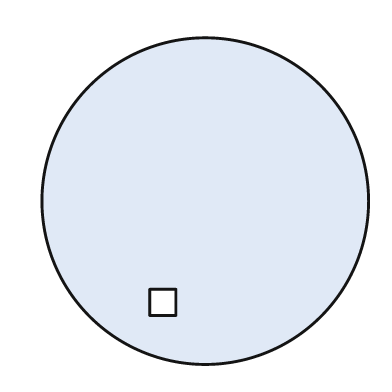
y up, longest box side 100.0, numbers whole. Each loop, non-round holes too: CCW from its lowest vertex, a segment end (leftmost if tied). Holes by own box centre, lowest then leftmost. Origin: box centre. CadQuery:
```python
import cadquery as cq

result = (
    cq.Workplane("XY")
    .moveTo(0.0, 0.0)
    .circle(50.0)
    .moveTo(-17.0, -35.0)
    .lineTo(-9.0, -35.0)
    .lineTo(-9.0, -27.0)
    .lineTo(-17.0, -27.0)
    .close()
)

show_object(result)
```